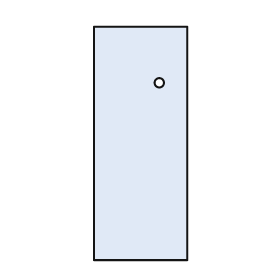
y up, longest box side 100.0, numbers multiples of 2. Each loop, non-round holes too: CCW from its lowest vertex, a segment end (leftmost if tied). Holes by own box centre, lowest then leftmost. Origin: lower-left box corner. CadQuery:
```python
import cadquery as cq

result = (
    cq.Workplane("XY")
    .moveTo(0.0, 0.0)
    .lineTo(40.0, 0.0)
    .lineTo(40.0, 100.0)
    .lineTo(0.0, 100.0)
    .close()
    .moveTo(28.0, 76.0)
    .circle(2.0)
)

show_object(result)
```